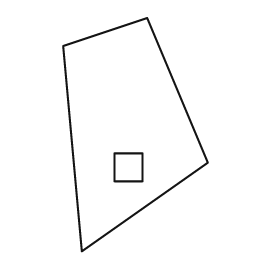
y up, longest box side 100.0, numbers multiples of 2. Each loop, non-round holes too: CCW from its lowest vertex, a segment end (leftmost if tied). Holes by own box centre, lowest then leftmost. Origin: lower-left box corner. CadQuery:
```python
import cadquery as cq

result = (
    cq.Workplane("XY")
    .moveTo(8.0, 0.0)
    .lineTo(62.0, 38.0)
    .lineTo(36.0, 100.0)
    .lineTo(0.0, 88.0)
    .close()
    .moveTo(22.0, 30.0)
    .lineTo(34.0, 30.0)
    .lineTo(34.0, 42.0)
    .lineTo(22.0, 42.0)
    .close()
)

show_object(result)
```